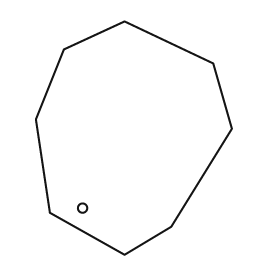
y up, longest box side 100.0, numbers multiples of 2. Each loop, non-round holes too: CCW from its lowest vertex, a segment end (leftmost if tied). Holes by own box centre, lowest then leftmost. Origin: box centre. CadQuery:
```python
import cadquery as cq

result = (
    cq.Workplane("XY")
    .moveTo(-4.0, -50.0)
    .lineTo(16.0, -38.0)
    .lineTo(42.0, 4.0)
    .lineTo(34.0, 32.0)
    .lineTo(-4.0, 50.0)
    .lineTo(-30.0, 38.0)
    .lineTo(-42.0, 8.0)
    .lineTo(-36.0, -32.0)
    .close()
    .moveTo(-22.0, -30.0)
    .circle(2.0)
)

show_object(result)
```